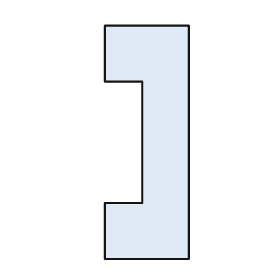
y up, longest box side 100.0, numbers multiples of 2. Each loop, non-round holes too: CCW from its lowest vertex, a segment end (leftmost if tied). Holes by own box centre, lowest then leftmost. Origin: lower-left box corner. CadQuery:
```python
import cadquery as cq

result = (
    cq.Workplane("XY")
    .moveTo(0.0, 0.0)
    .lineTo(36.0, 0.0)
    .lineTo(36.0, 100.0)
    .lineTo(0.0, 100.0)
    .lineTo(0.0, 76.0)
    .lineTo(16.0, 76.0)
    .lineTo(16.0, 24.0)
    .lineTo(0.0, 24.0)
    .close()
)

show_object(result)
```